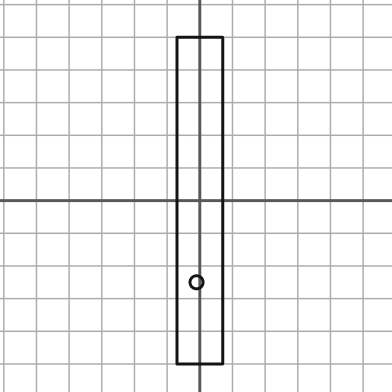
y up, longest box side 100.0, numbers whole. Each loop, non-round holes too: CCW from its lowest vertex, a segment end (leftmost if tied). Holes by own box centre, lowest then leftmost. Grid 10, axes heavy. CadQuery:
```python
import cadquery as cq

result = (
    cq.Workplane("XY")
    .moveTo(-7.0, -50.0)
    .lineTo(7.0, -50.0)
    .lineTo(7.0, 50.0)
    .lineTo(-7.0, 50.0)
    .close()
    .moveTo(-1.0, -25.0)
    .circle(2.0)
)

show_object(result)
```